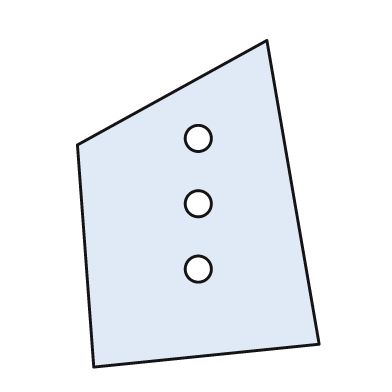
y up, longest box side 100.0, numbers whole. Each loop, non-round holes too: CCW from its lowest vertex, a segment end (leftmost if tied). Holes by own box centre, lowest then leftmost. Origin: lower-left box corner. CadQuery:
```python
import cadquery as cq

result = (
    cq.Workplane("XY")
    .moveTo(5.0, 0.0)
    .lineTo(74.0, 7.0)
    .lineTo(58.0, 100.0)
    .lineTo(0.0, 68.0)
    .close()
    .moveTo(37.0, 30.0)
    .circle(4.0)
    .moveTo(37.0, 50.0)
    .circle(4.0)
    .moveTo(37.0, 70.0)
    .circle(4.0)
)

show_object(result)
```